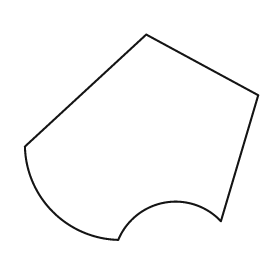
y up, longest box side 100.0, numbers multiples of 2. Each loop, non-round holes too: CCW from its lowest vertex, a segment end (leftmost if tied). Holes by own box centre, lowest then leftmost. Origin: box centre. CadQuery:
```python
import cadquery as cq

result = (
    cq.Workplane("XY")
    .moveTo(-10.0, -44.0)
    .threePointArc((10.0, -28.0), (34.0, -36.0))
    .lineTo(50.0, 18.0)
    .lineTo(2.0, 44.0)
    .lineTo(-50.0, -4.0)
    .threePointArc((-38.0, -32.0), (-10.0, -44.0))
    .close()
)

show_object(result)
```